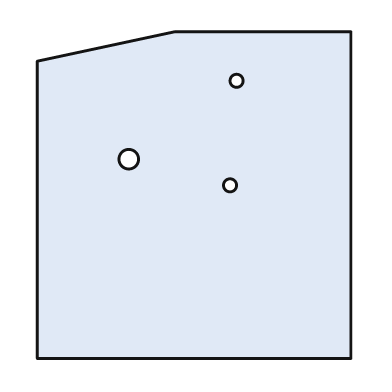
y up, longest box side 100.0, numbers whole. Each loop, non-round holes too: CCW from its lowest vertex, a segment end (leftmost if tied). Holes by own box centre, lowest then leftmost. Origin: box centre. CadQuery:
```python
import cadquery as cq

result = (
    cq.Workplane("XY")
    .moveTo(-48.0, -50.0)
    .lineTo(48.0, -50.0)
    .lineTo(48.0, 50.0)
    .lineTo(-6.0, 50.0)
    .lineTo(-48.0, 41.0)
    .close()
    .moveTo(11.0, 3.0)
    .circle(2.0)
    .moveTo(-20.0, 11.0)
    .circle(3.0)
    .moveTo(13.0, 35.0)
    .circle(2.0)
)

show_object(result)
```